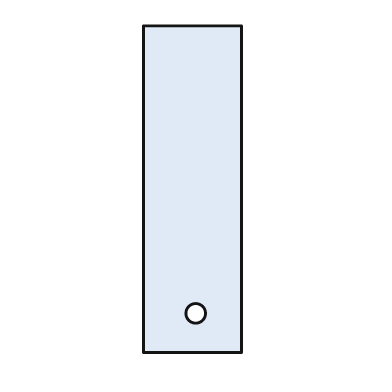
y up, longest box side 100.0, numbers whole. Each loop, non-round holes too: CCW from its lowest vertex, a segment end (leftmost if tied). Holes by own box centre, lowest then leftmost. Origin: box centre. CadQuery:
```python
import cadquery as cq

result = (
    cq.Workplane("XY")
    .moveTo(-15.0, -50.0)
    .lineTo(15.0, -50.0)
    .lineTo(15.0, 50.0)
    .lineTo(-15.0, 50.0)
    .close()
    .moveTo(1.0, -38.0)
    .circle(3.0)
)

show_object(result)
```